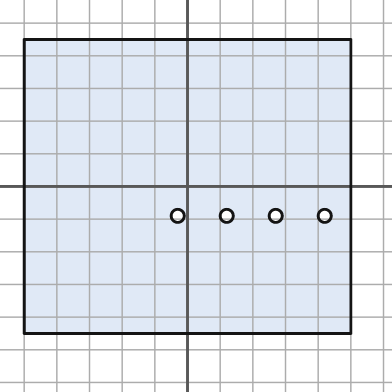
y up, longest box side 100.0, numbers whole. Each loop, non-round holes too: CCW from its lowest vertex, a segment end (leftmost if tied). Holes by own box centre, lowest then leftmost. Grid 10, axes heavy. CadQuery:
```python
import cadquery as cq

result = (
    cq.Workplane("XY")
    .moveTo(-50.0, -45.0)
    .lineTo(50.0, -45.0)
    .lineTo(50.0, 45.0)
    .lineTo(-50.0, 45.0)
    .close()
    .moveTo(-3.0, -9.0)
    .circle(2.0)
    .moveTo(12.0, -9.0)
    .circle(2.0)
    .moveTo(27.0, -9.0)
    .circle(2.0)
    .moveTo(42.0, -9.0)
    .circle(2.0)
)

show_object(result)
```